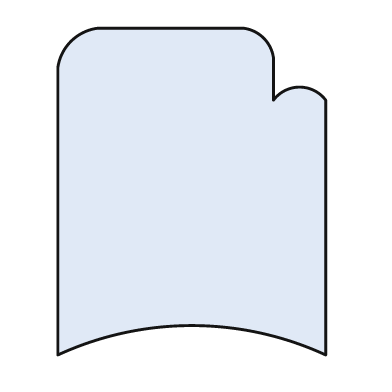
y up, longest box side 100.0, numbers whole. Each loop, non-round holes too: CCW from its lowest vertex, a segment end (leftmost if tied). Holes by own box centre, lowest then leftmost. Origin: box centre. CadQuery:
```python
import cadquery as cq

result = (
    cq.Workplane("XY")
    .moveTo(-41.0, -50.0)
    .threePointArc((0.0, -41.0), (41.0, -50.0))
    .lineTo(41.0, 28.0)
    .threePointArc((33.0, 32.0), (25.0, 28.0))
    .lineTo(25.0, 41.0)
    .threePointArc((22.0, 47.0), (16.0, 50.0))
    .lineTo(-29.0, 50.0)
    .threePointArc((-37.0, 46.0), (-41.0, 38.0))
    .close()
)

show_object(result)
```